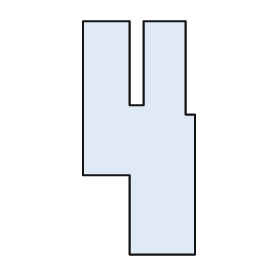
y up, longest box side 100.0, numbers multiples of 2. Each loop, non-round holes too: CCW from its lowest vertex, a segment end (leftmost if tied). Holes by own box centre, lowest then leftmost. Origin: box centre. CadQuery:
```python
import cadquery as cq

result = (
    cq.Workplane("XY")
    .moveTo(-4.0, -50.0)
    .lineTo(24.0, -50.0)
    .lineTo(24.0, 10.0)
    .lineTo(20.0, 10.0)
    .lineTo(20.0, 50.0)
    .lineTo(2.0, 50.0)
    .lineTo(2.0, 14.0)
    .lineTo(-4.0, 14.0)
    .lineTo(-4.0, 50.0)
    .lineTo(-24.0, 50.0)
    .lineTo(-24.0, -16.0)
    .lineTo(-4.0, -16.0)
    .close()
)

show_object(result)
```